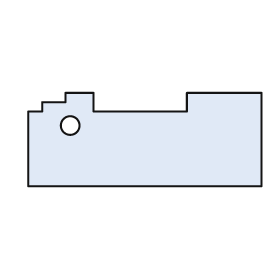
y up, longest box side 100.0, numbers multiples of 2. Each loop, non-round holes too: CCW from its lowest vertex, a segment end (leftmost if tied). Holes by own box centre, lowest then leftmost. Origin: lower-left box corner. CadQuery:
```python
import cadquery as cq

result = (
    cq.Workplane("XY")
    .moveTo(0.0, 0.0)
    .lineTo(100.0, 0.0)
    .lineTo(100.0, 40.0)
    .lineTo(68.0, 40.0)
    .lineTo(68.0, 32.0)
    .lineTo(28.0, 32.0)
    .lineTo(28.0, 40.0)
    .lineTo(16.0, 40.0)
    .lineTo(16.0, 36.0)
    .lineTo(6.0, 36.0)
    .lineTo(6.0, 32.0)
    .lineTo(0.0, 32.0)
    .close()
    .moveTo(18.0, 26.0)
    .circle(4.0)
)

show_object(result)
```